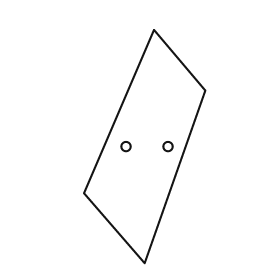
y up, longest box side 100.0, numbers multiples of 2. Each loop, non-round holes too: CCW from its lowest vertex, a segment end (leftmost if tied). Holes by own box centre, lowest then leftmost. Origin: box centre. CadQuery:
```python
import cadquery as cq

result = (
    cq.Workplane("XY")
    .moveTo(0.0, -50.0)
    .lineTo(26.0, 24.0)
    .lineTo(4.0, 50.0)
    .lineTo(-26.0, -20.0)
    .close()
    .moveTo(-8.0, 0.0)
    .circle(2.0)
    .moveTo(10.0, 0.0)
    .circle(2.0)
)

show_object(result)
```